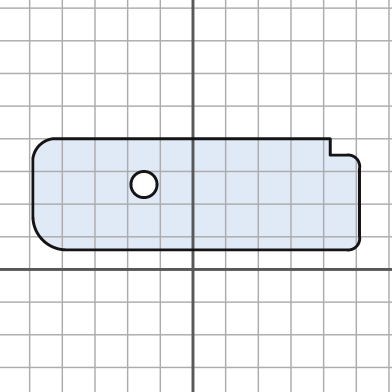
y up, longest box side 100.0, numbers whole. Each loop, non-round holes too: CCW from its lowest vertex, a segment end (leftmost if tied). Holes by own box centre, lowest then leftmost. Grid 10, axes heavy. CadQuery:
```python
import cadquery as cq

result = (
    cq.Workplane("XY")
    .moveTo(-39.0, 6.0)
    .lineTo(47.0, 6.0)
    .threePointArc((50.0, 7.0), (51.0, 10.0))
    .lineTo(51.0, 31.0)
    .threePointArc((50.0, 34.0), (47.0, 35.0))
    .lineTo(42.0, 35.0)
    .lineTo(42.0, 40.0)
    .lineTo(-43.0, 40.0)
    .threePointArc((-47.0, 38.0), (-49.0, 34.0))
    .lineTo(-49.0, 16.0)
    .threePointArc((-46.0, 9.0), (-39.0, 6.0))
    .close()
    .moveTo(-15.0, 26.0)
    .circle(4.0)
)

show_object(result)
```